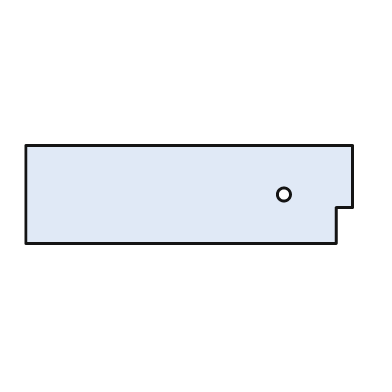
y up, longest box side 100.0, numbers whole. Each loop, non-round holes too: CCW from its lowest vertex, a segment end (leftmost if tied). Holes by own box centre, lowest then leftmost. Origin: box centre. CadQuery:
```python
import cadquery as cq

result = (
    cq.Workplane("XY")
    .moveTo(-50.0, -15.0)
    .lineTo(45.0, -15.0)
    .lineTo(45.0, -4.0)
    .lineTo(50.0, -4.0)
    .lineTo(50.0, 15.0)
    .lineTo(-50.0, 15.0)
    .close()
    .moveTo(29.0, 0.0)
    .circle(2.0)
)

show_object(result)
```